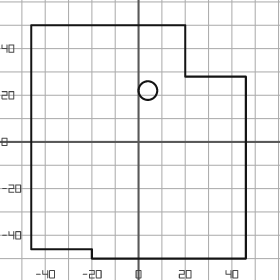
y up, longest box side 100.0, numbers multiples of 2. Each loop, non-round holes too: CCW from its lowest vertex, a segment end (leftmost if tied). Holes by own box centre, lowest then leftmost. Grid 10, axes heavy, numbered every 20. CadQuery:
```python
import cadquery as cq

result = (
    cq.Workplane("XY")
    .moveTo(-20.0, -50.0)
    .lineTo(46.0, -50.0)
    .lineTo(46.0, 28.0)
    .lineTo(20.0, 28.0)
    .lineTo(20.0, 50.0)
    .lineTo(-46.0, 50.0)
    .lineTo(-46.0, -46.0)
    .lineTo(-20.0, -46.0)
    .close()
    .moveTo(4.0, 22.0)
    .circle(4.0)
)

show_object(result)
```